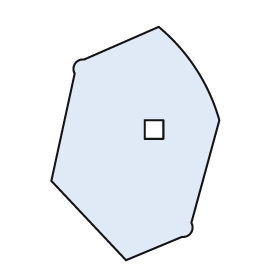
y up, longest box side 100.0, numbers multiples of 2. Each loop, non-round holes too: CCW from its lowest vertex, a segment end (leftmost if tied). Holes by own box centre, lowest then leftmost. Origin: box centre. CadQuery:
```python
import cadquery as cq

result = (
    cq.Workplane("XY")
    .moveTo(-4.0, -50.0)
    .lineTo(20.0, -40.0)
    .threePointArc((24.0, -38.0), (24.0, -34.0))
    .lineTo(36.0, 10.0)
    .threePointArc((26.0, 32.0), (10.0, 50.0))
    .lineTo(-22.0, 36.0)
    .threePointArc((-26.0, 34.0), (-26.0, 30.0))
    .lineTo(-36.0, -16.0)
    .close()
    .moveTo(4.0, 2.0)
    .lineTo(12.0, 2.0)
    .lineTo(12.0, 10.0)
    .lineTo(4.0, 10.0)
    .close()
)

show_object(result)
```